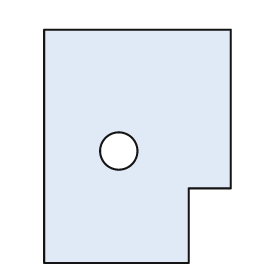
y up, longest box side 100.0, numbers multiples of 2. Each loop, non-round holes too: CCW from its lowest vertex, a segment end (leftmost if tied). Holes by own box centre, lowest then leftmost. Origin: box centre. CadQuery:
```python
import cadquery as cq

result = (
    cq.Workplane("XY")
    .moveTo(-40.0, -50.0)
    .lineTo(22.0, -50.0)
    .lineTo(22.0, -18.0)
    .lineTo(40.0, -18.0)
    .lineTo(40.0, 50.0)
    .lineTo(-40.0, 50.0)
    .close()
    .moveTo(-8.0, -2.0)
    .circle(8.0)
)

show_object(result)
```